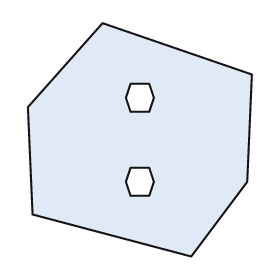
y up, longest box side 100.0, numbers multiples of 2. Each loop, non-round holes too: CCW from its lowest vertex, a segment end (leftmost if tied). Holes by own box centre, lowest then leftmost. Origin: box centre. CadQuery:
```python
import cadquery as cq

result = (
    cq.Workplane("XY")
    .moveTo(22.0, -50.0)
    .lineTo(46.0, -18.0)
    .lineTo(48.0, 28.0)
    .lineTo(-16.0, 50.0)
    .lineTo(-48.0, 14.0)
    .lineTo(-46.0, -32.0)
    .close()
    .moveTo(-4.0, -24.0)
    .lineTo(4.0, -24.0)
    .lineTo(6.0, -18.0)
    .lineTo(4.0, -12.0)
    .lineTo(-4.0, -12.0)
    .lineTo(-6.0, -18.0)
    .close()
    .moveTo(-4.0, 12.0)
    .lineTo(4.0, 12.0)
    .lineTo(6.0, 18.0)
    .lineTo(4.0, 24.0)
    .lineTo(-4.0, 24.0)
    .lineTo(-6.0, 18.0)
    .close()
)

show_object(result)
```